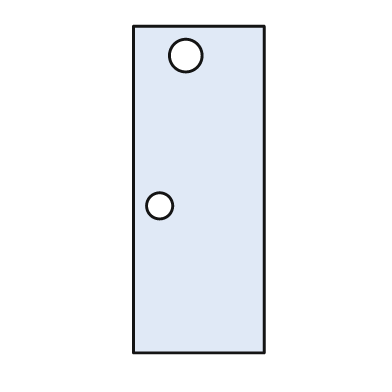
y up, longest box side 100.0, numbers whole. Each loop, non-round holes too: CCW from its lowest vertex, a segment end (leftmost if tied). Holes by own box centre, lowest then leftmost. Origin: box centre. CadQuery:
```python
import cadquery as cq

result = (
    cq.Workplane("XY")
    .moveTo(-20.0, -50.0)
    .lineTo(20.0, -50.0)
    .lineTo(20.0, 50.0)
    .lineTo(-20.0, 50.0)
    .close()
    .moveTo(-12.0, -5.0)
    .circle(4.0)
    .moveTo(-4.0, 41.0)
    .circle(5.0)
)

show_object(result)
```